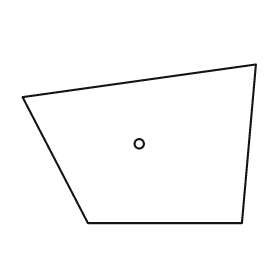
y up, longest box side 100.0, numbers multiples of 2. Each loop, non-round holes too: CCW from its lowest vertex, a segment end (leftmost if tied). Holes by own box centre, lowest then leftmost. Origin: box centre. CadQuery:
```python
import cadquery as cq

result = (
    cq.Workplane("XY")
    .moveTo(-22.0, -34.0)
    .lineTo(44.0, -34.0)
    .lineTo(50.0, 34.0)
    .lineTo(-50.0, 20.0)
    .close()
    .moveTo(0.0, 0.0)
    .circle(2.0)
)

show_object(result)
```